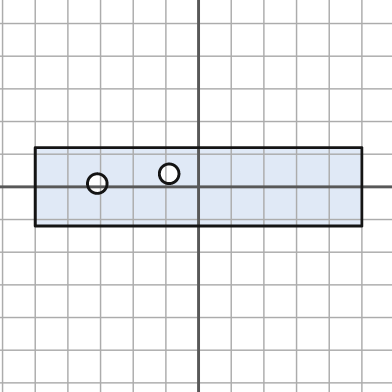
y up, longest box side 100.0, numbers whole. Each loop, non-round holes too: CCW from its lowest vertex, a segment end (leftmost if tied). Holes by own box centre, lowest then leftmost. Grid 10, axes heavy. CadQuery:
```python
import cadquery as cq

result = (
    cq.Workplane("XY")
    .moveTo(-50.0, -12.0)
    .lineTo(50.0, -12.0)
    .lineTo(50.0, 12.0)
    .lineTo(-50.0, 12.0)
    .close()
    .moveTo(-31.0, 1.0)
    .circle(3.0)
    .moveTo(-9.0, 4.0)
    .circle(3.0)
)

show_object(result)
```